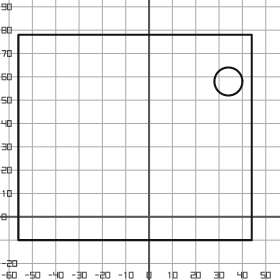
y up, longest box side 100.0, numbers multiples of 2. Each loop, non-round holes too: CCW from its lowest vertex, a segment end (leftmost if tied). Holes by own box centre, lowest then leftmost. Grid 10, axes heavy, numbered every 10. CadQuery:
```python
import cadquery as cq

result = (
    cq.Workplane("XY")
    .moveTo(-56.0, -10.0)
    .lineTo(44.0, -10.0)
    .lineTo(44.0, 78.0)
    .lineTo(-56.0, 78.0)
    .close()
    .moveTo(34.0, 58.0)
    .circle(6.0)
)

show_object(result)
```